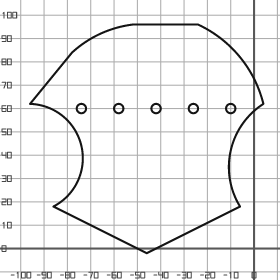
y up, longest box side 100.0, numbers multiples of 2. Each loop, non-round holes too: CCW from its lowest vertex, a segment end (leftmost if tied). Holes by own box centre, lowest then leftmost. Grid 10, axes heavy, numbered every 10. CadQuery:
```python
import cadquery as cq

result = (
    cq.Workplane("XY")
    .moveTo(-46.0, -2.0)
    .lineTo(-6.0, 18.0)
    .threePointArc((-10.0, 42.0), (4.0, 62.0))
    .threePointArc((-6.0, 82.0), (-24.0, 96.0))
    .lineTo(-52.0, 96.0)
    .threePointArc((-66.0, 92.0), (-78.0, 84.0))
    .lineTo(-96.0, 62.0)
    .threePointArc((-74.0, 44.0), (-86.0, 18.0))
    .close()
    .moveTo(-74.0, 60.0)
    .circle(2.0)
    .moveTo(-58.0, 60.0)
    .circle(2.0)
    .moveTo(-42.0, 60.0)
    .circle(2.0)
    .moveTo(-26.0, 60.0)
    .circle(2.0)
    .moveTo(-10.0, 60.0)
    .circle(2.0)
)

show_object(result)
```